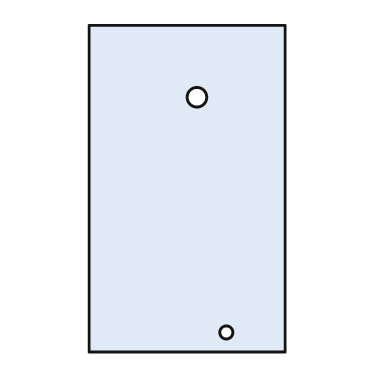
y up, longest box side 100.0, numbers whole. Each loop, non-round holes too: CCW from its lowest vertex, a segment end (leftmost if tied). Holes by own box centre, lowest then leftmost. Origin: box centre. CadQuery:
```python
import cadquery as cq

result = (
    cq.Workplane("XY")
    .moveTo(-30.0, -50.0)
    .lineTo(30.0, -50.0)
    .lineTo(30.0, 50.0)
    .lineTo(-30.0, 50.0)
    .close()
    .moveTo(12.0, -44.0)
    .circle(2.0)
    .moveTo(3.0, 28.0)
    .circle(3.0)
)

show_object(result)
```